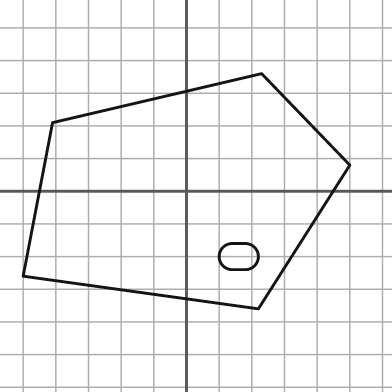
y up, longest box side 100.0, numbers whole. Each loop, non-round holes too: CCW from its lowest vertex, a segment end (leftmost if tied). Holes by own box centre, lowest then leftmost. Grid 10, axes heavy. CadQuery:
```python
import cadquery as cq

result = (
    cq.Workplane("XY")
    .moveTo(22.0, -36.0)
    .lineTo(50.0, 8.0)
    .lineTo(23.0, 36.0)
    .lineTo(-41.0, 21.0)
    .lineTo(-50.0, -26.0)
    .close()
    .moveTo(14.0, -24.0)
    .lineTo(18.0, -24.0)
    .threePointArc((22.0, -20.0), (18.0, -16.0))
    .lineTo(14.0, -16.0)
    .threePointArc((10.0, -20.0), (14.0, -24.0))
    .close()
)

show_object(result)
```